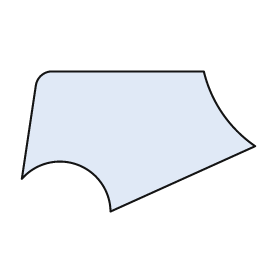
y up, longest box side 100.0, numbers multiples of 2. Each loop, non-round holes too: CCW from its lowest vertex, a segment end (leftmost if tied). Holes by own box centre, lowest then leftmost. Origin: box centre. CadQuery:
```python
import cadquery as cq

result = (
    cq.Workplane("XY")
    .moveTo(-12.0, -30.0)
    .lineTo(50.0, -2.0)
    .threePointArc((36.0, 12.0), (28.0, 30.0))
    .lineTo(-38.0, 30.0)
    .threePointArc((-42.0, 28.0), (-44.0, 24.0))
    .lineTo(-50.0, -16.0)
    .threePointArc((-26.0, -10.0), (-12.0, -30.0))
    .close()
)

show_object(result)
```